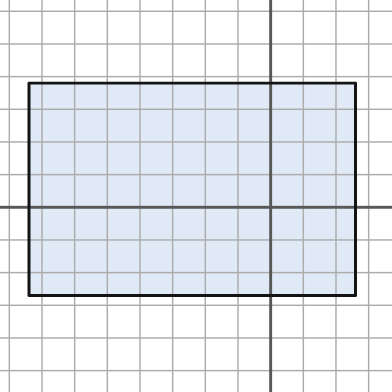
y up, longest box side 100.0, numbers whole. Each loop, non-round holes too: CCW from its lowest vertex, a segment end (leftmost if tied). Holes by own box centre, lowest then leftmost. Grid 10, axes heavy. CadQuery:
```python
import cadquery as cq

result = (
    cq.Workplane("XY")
    .moveTo(-74.0, -27.0)
    .lineTo(26.0, -27.0)
    .lineTo(26.0, 38.0)
    .lineTo(-74.0, 38.0)
    .close()
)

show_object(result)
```